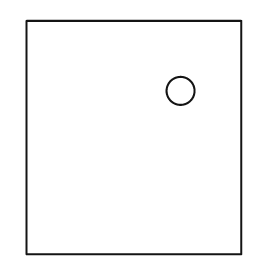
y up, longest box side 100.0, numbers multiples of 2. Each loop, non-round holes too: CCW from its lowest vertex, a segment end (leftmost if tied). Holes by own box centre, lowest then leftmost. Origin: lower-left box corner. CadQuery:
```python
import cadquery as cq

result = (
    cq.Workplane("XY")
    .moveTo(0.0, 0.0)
    .lineTo(92.0, 0.0)
    .lineTo(92.0, 100.0)
    .lineTo(0.0, 100.0)
    .close()
    .moveTo(66.0, 70.0)
    .circle(6.0)
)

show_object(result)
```